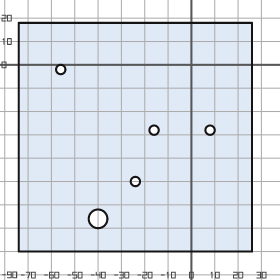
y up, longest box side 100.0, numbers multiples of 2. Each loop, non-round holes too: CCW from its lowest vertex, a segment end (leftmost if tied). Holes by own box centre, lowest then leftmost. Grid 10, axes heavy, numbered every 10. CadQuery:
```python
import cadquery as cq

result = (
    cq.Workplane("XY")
    .moveTo(-74.0, -80.0)
    .lineTo(26.0, -80.0)
    .lineTo(26.0, 18.0)
    .lineTo(-74.0, 18.0)
    .close()
    .moveTo(-40.0, -66.0)
    .circle(4.0)
    .moveTo(-24.0, -50.0)
    .circle(2.0)
    .moveTo(-16.0, -28.0)
    .circle(2.0)
    .moveTo(8.0, -28.0)
    .circle(2.0)
    .moveTo(-56.0, -2.0)
    .circle(2.0)
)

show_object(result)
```